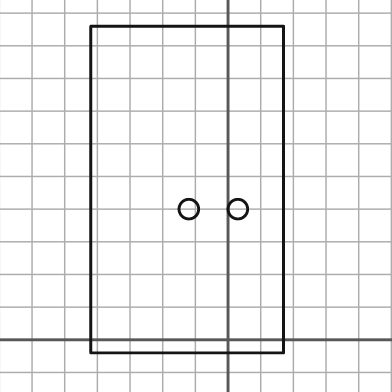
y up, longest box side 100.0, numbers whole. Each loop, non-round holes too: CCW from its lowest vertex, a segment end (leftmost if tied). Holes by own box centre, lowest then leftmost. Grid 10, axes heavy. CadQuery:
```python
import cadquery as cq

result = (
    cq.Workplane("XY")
    .moveTo(-42.0, -4.0)
    .lineTo(17.0, -4.0)
    .lineTo(17.0, 96.0)
    .lineTo(-42.0, 96.0)
    .close()
    .moveTo(-12.0, 40.0)
    .circle(3.0)
    .moveTo(3.0, 40.0)
    .circle(3.0)
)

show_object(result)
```